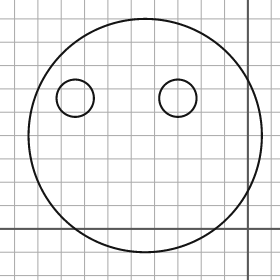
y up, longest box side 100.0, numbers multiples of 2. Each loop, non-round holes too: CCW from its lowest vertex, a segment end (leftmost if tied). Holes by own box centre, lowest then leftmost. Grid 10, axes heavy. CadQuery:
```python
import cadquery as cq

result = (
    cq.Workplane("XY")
    .moveTo(-44.0, 40.0)
    .circle(50.0)
    .moveTo(-74.0, 56.0)
    .circle(8.0)
    .moveTo(-30.0, 56.0)
    .circle(8.0)
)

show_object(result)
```